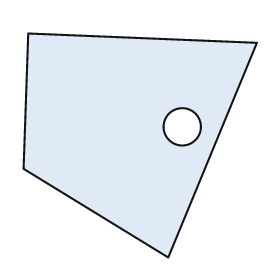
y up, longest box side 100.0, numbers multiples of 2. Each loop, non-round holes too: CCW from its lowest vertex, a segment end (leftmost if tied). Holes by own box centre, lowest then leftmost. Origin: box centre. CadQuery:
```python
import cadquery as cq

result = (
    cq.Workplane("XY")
    .moveTo(12.0, -48.0)
    .lineTo(50.0, 44.0)
    .lineTo(-48.0, 48.0)
    .lineTo(-50.0, -10.0)
    .close()
    .moveTo(18.0, 8.0)
    .circle(8.0)
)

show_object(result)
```